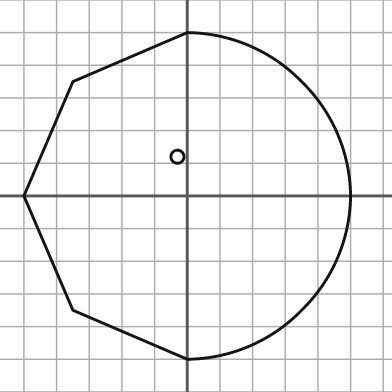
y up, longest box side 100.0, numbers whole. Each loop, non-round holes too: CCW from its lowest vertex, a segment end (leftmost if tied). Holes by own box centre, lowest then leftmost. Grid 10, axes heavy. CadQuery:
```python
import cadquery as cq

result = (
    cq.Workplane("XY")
    .moveTo(0.0, -50.0)
    .threePointArc((19.0, -46.0), (35.0, -35.0))
    .threePointArc((46.0, -19.0), (50.0, 0.0))
    .threePointArc((46.0, 19.0), (35.0, 35.0))
    .threePointArc((19.0, 46.0), (0.0, 50.0))
    .lineTo(-35.0, 35.0)
    .lineTo(-50.0, 0.0)
    .lineTo(-35.0, -35.0)
    .close()
    .moveTo(-3.0, 12.0)
    .circle(2.0)
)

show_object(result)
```